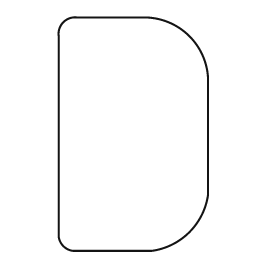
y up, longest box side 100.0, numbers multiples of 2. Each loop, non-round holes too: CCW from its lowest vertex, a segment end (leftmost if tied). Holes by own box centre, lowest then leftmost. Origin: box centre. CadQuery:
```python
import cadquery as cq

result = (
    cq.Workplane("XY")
    .moveTo(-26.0, -50.0)
    .lineTo(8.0, -50.0)
    .threePointArc((24.0, -42.0), (32.0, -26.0))
    .lineTo(32.0, 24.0)
    .threePointArc((24.0, 42.0), (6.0, 50.0))
    .lineTo(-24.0, 50.0)
    .threePointArc((-30.0, 48.0), (-32.0, 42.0))
    .lineTo(-32.0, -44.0)
    .threePointArc((-30.0, -48.0), (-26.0, -50.0))
    .close()
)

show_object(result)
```